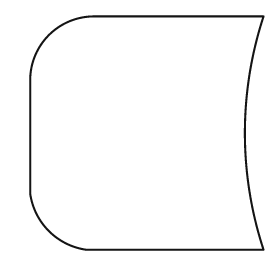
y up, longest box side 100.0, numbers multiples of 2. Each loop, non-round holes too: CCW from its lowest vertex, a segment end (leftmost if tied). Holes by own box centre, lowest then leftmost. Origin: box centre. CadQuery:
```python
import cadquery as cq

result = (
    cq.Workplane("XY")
    .moveTo(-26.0, -50.0)
    .lineTo(50.0, -50.0)
    .threePointArc((42.0, 0.0), (50.0, 50.0))
    .lineTo(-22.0, 50.0)
    .threePointArc((-42.0, 42.0), (-50.0, 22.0))
    .lineTo(-50.0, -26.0)
    .threePointArc((-42.0, -42.0), (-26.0, -50.0))
    .close()
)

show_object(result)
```